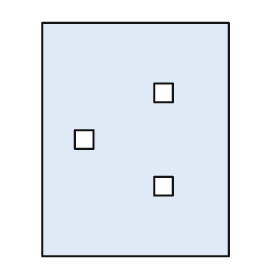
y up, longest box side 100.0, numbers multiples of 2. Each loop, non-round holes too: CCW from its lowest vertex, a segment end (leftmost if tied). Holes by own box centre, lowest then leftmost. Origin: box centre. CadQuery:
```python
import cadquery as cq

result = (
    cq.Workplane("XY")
    .moveTo(-40.0, -50.0)
    .lineTo(40.0, -50.0)
    .lineTo(40.0, 50.0)
    .lineTo(-40.0, 50.0)
    .close()
    .moveTo(8.0, -24.0)
    .lineTo(16.0, -24.0)
    .lineTo(16.0, -16.0)
    .lineTo(8.0, -16.0)
    .close()
    .moveTo(-26.0, -4.0)
    .lineTo(-18.0, -4.0)
    .lineTo(-18.0, 4.0)
    .lineTo(-26.0, 4.0)
    .close()
    .moveTo(8.0, 16.0)
    .lineTo(16.0, 16.0)
    .lineTo(16.0, 24.0)
    .lineTo(8.0, 24.0)
    .close()
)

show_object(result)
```